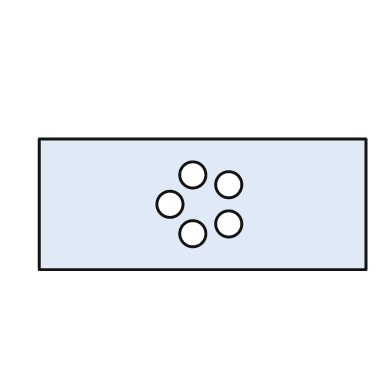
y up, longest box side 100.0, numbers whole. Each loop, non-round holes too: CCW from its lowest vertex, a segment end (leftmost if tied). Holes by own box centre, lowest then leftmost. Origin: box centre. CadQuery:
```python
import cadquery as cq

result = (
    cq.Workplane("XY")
    .moveTo(-50.0, -20.0)
    .lineTo(50.0, -20.0)
    .lineTo(50.0, 20.0)
    .lineTo(-50.0, 20.0)
    .close()
    .moveTo(-3.0, -9.0)
    .circle(4.0)
    .moveTo(8.0, -6.0)
    .circle(4.0)
    .moveTo(-10.0, 0.0)
    .circle(4.0)
    .moveTo(8.0, 6.0)
    .circle(4.0)
    .moveTo(-3.0, 9.0)
    .circle(4.0)
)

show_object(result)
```